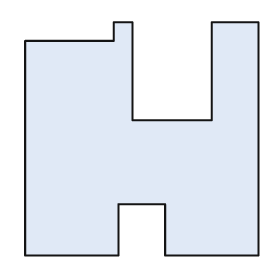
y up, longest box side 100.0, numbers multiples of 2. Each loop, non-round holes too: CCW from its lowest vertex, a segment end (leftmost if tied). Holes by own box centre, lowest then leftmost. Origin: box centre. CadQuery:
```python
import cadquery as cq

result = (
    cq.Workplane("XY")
    .moveTo(-50.0, -50.0)
    .lineTo(-10.0, -50.0)
    .lineTo(-10.0, -28.0)
    .lineTo(10.0, -28.0)
    .lineTo(10.0, -50.0)
    .lineTo(50.0, -50.0)
    .lineTo(50.0, 50.0)
    .lineTo(30.0, 50.0)
    .lineTo(30.0, 8.0)
    .lineTo(-4.0, 8.0)
    .lineTo(-4.0, 50.0)
    .lineTo(-12.0, 50.0)
    .lineTo(-12.0, 42.0)
    .lineTo(-50.0, 42.0)
    .close()
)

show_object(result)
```